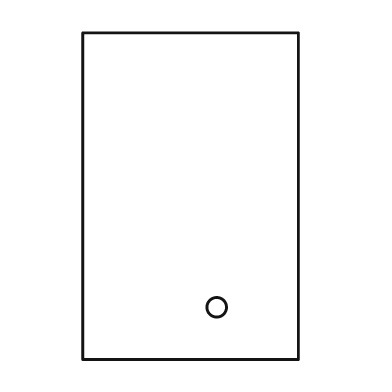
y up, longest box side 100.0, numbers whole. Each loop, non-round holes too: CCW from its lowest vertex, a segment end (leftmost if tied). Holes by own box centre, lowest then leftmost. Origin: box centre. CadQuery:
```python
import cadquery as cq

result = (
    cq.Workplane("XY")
    .moveTo(-33.0, -50.0)
    .lineTo(33.0, -50.0)
    .lineTo(33.0, 50.0)
    .lineTo(-33.0, 50.0)
    .close()
    .moveTo(8.0, -34.0)
    .circle(3.0)
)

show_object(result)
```